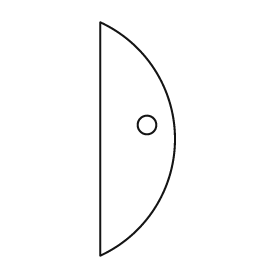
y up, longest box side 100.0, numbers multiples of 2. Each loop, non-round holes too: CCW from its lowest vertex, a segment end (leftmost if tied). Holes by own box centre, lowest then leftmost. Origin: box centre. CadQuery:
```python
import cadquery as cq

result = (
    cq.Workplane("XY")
    .moveTo(-16.0, -50.0)
    .threePointArc((16.0, 0.0), (-16.0, 50.0))
    .close()
    .moveTo(4.0, 6.0)
    .circle(4.0)
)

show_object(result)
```